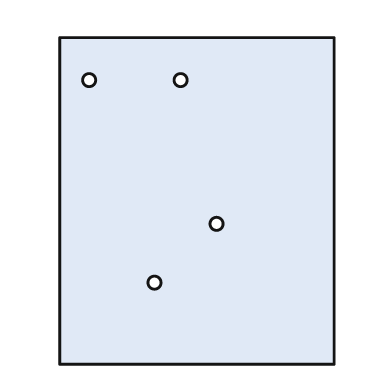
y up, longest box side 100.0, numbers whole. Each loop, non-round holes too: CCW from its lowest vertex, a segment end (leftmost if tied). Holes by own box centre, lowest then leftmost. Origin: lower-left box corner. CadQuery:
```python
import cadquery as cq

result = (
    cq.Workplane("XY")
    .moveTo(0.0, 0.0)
    .lineTo(84.0, 0.0)
    .lineTo(84.0, 100.0)
    .lineTo(0.0, 100.0)
    .close()
    .moveTo(29.0, 25.0)
    .circle(2.0)
    .moveTo(48.0, 43.0)
    .circle(2.0)
    .moveTo(9.0, 87.0)
    .circle(2.0)
    .moveTo(37.0, 87.0)
    .circle(2.0)
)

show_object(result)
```